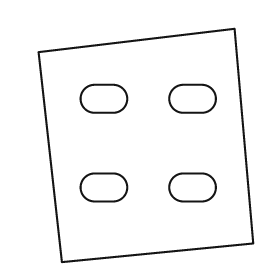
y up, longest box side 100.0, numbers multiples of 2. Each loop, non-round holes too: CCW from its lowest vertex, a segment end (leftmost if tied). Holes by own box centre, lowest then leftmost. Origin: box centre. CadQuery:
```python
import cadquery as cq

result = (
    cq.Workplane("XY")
    .moveTo(-36.0, -50.0)
    .lineTo(46.0, -42.0)
    .lineTo(38.0, 50.0)
    .lineTo(-46.0, 40.0)
    .close()
    .moveTo(-22.0, -24.0)
    .lineTo(-14.0, -24.0)
    .threePointArc((-8.0, -18.0), (-14.0, -12.0))
    .lineTo(-22.0, -12.0)
    .threePointArc((-28.0, -18.0), (-22.0, -24.0))
    .close()
    .moveTo(16.0, -24.0)
    .lineTo(24.0, -24.0)
    .threePointArc((30.0, -18.0), (24.0, -12.0))
    .lineTo(16.0, -12.0)
    .threePointArc((10.0, -18.0), (16.0, -24.0))
    .close()
    .moveTo(-22.0, 14.0)
    .lineTo(-14.0, 14.0)
    .threePointArc((-8.0, 20.0), (-14.0, 26.0))
    .lineTo(-22.0, 26.0)
    .threePointArc((-28.0, 20.0), (-22.0, 14.0))
    .close()
    .moveTo(16.0, 14.0)
    .lineTo(24.0, 14.0)
    .threePointArc((30.0, 20.0), (24.0, 26.0))
    .lineTo(16.0, 26.0)
    .threePointArc((10.0, 20.0), (16.0, 14.0))
    .close()
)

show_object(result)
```